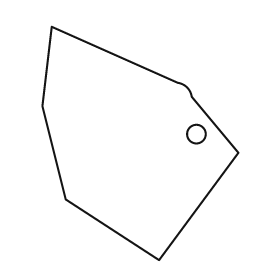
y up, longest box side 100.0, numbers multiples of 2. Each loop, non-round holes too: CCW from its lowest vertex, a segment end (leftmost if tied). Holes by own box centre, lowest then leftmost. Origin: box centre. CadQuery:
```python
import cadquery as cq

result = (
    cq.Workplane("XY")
    .moveTo(8.0, -50.0)
    .lineTo(42.0, -4.0)
    .lineTo(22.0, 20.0)
    .threePointArc((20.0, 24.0), (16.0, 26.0))
    .lineTo(-38.0, 50.0)
    .lineTo(-42.0, 16.0)
    .lineTo(-32.0, -24.0)
    .close()
    .moveTo(24.0, 4.0)
    .circle(4.0)
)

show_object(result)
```